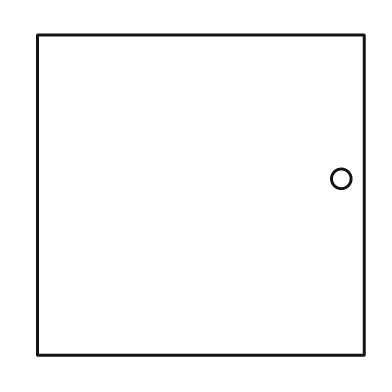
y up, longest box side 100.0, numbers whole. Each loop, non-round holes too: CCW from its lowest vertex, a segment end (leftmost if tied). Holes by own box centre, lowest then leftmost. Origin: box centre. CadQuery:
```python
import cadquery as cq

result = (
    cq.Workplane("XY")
    .moveTo(-50.0, -49.0)
    .lineTo(50.0, -49.0)
    .lineTo(50.0, 49.0)
    .lineTo(-50.0, 49.0)
    .close()
    .moveTo(43.0, 5.0)
    .circle(3.0)
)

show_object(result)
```